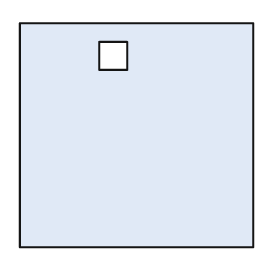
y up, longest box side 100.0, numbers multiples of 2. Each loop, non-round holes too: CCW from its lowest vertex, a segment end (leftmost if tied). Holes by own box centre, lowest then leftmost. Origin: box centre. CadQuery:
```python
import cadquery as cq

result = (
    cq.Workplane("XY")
    .moveTo(-50.0, -48.0)
    .lineTo(50.0, -48.0)
    .lineTo(50.0, 48.0)
    .lineTo(-50.0, 48.0)
    .close()
    .moveTo(-16.0, 28.0)
    .lineTo(-4.0, 28.0)
    .lineTo(-4.0, 40.0)
    .lineTo(-16.0, 40.0)
    .close()
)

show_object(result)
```